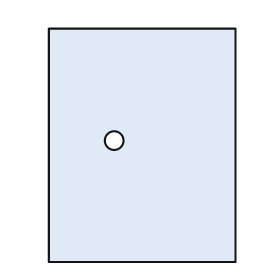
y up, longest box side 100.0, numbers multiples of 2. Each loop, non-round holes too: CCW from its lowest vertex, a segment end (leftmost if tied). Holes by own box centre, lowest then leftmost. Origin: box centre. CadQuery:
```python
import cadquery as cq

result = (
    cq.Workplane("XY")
    .moveTo(-40.0, -50.0)
    .lineTo(40.0, -50.0)
    .lineTo(40.0, 50.0)
    .lineTo(-40.0, 50.0)
    .close()
    .moveTo(-12.0, 2.0)
    .circle(4.0)
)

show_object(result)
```